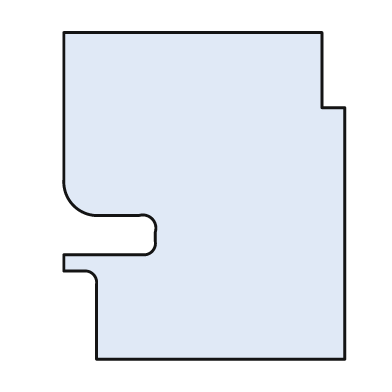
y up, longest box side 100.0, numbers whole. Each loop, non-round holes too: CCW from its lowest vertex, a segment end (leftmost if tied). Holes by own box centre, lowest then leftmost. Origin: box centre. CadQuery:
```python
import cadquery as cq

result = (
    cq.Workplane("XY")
    .moveTo(-33.0, -50.0)
    .lineTo(43.0, -50.0)
    .lineTo(43.0, 27.0)
    .lineTo(36.0, 27.0)
    .lineTo(36.0, 50.0)
    .lineTo(-43.0, 50.0)
    .lineTo(-43.0, 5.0)
    .threePointArc((-40.0, -3.0), (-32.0, -6.0))
    .lineTo(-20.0, -6.0)
    .threePointArc((-16.0, -7.0), (-15.0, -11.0))
    .lineTo(-15.0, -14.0)
    .threePointArc((-16.0, -17.0), (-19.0, -18.0))
    .lineTo(-43.0, -18.0)
    .lineTo(-43.0, -23.0)
    .lineTo(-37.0, -23.0)
    .threePointArc((-34.0, -24.0), (-33.0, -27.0))
    .close()
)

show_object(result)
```